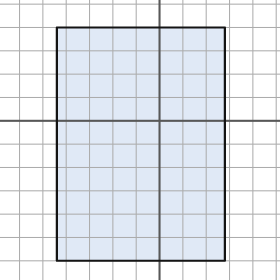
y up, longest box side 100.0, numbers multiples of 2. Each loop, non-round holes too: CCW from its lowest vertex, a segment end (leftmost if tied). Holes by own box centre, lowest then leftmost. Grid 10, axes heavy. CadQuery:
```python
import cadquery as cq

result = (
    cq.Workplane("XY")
    .moveTo(-44.0, -60.0)
    .lineTo(28.0, -60.0)
    .lineTo(28.0, 40.0)
    .lineTo(-44.0, 40.0)
    .close()
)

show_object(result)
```